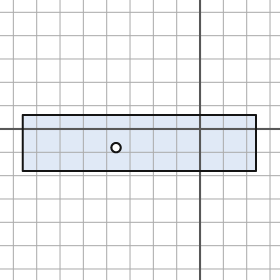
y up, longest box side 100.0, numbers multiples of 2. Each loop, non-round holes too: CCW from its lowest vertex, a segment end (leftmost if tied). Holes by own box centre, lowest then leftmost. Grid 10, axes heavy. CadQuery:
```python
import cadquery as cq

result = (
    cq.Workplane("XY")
    .moveTo(-76.0, -18.0)
    .lineTo(24.0, -18.0)
    .lineTo(24.0, 6.0)
    .lineTo(-76.0, 6.0)
    .close()
    .moveTo(-36.0, -8.0)
    .circle(2.0)
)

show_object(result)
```